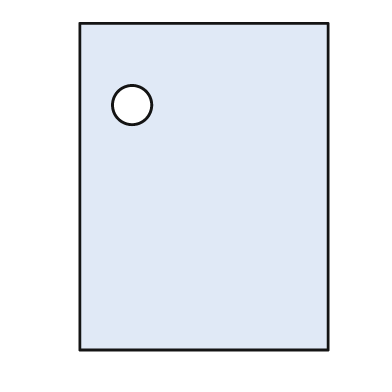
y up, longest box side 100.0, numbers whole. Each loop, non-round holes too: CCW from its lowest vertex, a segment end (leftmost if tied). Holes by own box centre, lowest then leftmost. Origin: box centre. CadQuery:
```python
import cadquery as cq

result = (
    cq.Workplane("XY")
    .moveTo(-38.0, -50.0)
    .lineTo(38.0, -50.0)
    .lineTo(38.0, 50.0)
    .lineTo(-38.0, 50.0)
    .close()
    .moveTo(-22.0, 25.0)
    .circle(6.0)
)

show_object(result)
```